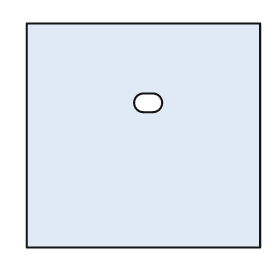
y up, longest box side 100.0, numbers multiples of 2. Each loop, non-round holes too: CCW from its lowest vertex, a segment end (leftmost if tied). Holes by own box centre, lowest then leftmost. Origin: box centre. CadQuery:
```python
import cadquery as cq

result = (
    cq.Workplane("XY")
    .moveTo(-50.0, -48.0)
    .lineTo(50.0, -48.0)
    .lineTo(50.0, 48.0)
    .lineTo(-50.0, 48.0)
    .close()
    .moveTo(0.0, 10.0)
    .lineTo(4.0, 10.0)
    .threePointArc((8.0, 14.0), (4.0, 18.0))
    .lineTo(0.0, 18.0)
    .threePointArc((-4.0, 14.0), (0.0, 10.0))
    .close()
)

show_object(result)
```